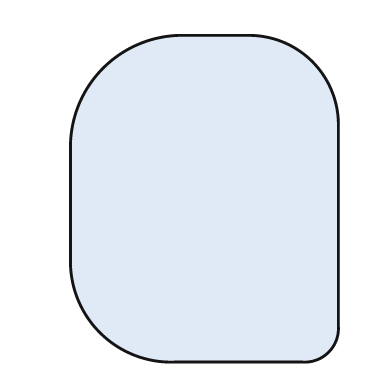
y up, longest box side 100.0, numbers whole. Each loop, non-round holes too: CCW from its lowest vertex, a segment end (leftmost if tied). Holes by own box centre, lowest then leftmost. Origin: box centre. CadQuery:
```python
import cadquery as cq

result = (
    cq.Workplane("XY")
    .moveTo(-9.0, -50.0)
    .lineTo(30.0, -50.0)
    .threePointArc((38.0, -47.0), (41.0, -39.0))
    .lineTo(41.0, 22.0)
    .threePointArc((33.0, 42.0), (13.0, 50.0))
    .lineTo(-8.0, 50.0)
    .threePointArc((-31.0, 40.0), (-41.0, 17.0))
    .lineTo(-41.0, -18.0)
    .threePointArc((-32.0, -41.0), (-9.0, -50.0))
    .close()
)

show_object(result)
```